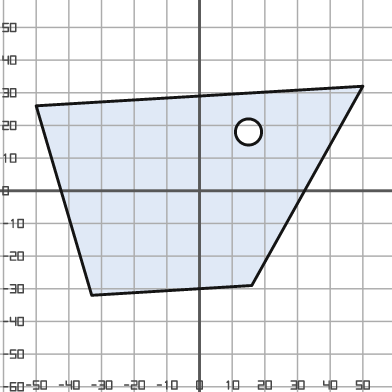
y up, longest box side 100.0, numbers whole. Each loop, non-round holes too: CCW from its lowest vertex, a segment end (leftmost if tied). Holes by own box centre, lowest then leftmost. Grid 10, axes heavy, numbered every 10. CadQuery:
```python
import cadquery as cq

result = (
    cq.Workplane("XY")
    .moveTo(-33.0, -32.0)
    .lineTo(16.0, -29.0)
    .lineTo(50.0, 32.0)
    .lineTo(-50.0, 26.0)
    .close()
    .moveTo(15.0, 18.0)
    .circle(4.0)
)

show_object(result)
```